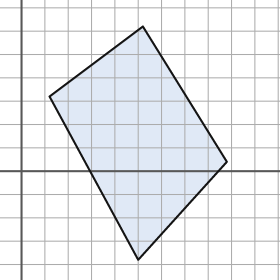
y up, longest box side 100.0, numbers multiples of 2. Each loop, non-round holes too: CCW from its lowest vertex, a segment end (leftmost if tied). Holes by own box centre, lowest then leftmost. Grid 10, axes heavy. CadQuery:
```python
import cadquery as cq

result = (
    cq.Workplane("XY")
    .moveTo(50.0, -38.0)
    .lineTo(88.0, 4.0)
    .lineTo(52.0, 62.0)
    .lineTo(12.0, 32.0)
    .close()
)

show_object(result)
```